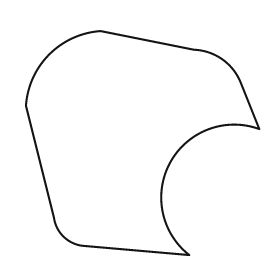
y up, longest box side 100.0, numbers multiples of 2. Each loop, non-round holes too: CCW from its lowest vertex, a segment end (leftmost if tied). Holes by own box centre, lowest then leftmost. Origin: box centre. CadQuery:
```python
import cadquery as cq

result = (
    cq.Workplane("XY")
    .moveTo(20.0, -48.0)
    .threePointArc((12.0, -8.0), (50.0, 6.0))
    .lineTo(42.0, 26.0)
    .threePointArc((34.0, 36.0), (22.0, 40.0))
    .lineTo(-18.0, 48.0)
    .threePointArc((-40.0, 38.0), (-50.0, 16.0))
    .lineTo(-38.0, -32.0)
    .threePointArc((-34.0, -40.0), (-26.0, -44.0))
    .close()
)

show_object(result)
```